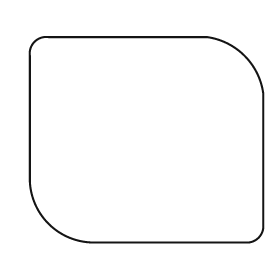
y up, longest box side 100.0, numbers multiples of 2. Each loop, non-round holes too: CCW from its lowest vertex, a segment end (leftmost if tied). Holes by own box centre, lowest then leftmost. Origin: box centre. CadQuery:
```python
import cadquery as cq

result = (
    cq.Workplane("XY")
    .moveTo(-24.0, -44.0)
    .lineTo(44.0, -44.0)
    .threePointArc((48.0, -42.0), (50.0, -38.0))
    .lineTo(50.0, 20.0)
    .threePointArc((42.0, 36.0), (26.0, 44.0))
    .lineTo(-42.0, 44.0)
    .threePointArc((-48.0, 42.0), (-50.0, 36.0))
    .lineTo(-50.0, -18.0)
    .threePointArc((-42.0, -36.0), (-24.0, -44.0))
    .close()
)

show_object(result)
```